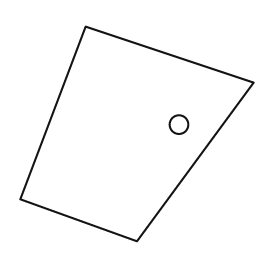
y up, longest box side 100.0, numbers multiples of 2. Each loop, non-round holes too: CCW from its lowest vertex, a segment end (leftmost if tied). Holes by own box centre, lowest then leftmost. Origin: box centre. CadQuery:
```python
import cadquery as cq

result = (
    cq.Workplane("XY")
    .moveTo(0.0, -46.0)
    .lineTo(50.0, 22.0)
    .lineTo(-22.0, 46.0)
    .lineTo(-50.0, -28.0)
    .close()
    .moveTo(18.0, 4.0)
    .circle(4.0)
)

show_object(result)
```